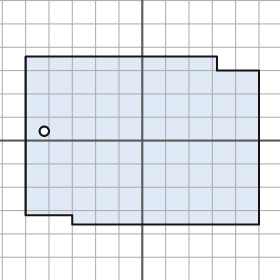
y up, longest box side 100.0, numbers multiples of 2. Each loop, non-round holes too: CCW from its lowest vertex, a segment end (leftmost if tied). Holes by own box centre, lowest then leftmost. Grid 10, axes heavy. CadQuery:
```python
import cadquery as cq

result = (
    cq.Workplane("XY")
    .moveTo(-30.0, -36.0)
    .lineTo(50.0, -36.0)
    .lineTo(50.0, 30.0)
    .lineTo(32.0, 30.0)
    .lineTo(32.0, 36.0)
    .lineTo(-50.0, 36.0)
    .lineTo(-50.0, -32.0)
    .lineTo(-30.0, -32.0)
    .close()
    .moveTo(-42.0, 4.0)
    .circle(2.0)
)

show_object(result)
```